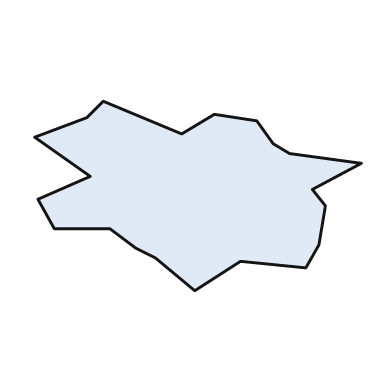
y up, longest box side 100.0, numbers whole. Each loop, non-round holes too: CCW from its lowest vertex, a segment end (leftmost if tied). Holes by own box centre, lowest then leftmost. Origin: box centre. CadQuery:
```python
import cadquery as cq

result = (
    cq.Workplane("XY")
    .moveTo(-1.0, -29.0)
    .lineTo(13.0, -20.0)
    .lineTo(33.0, -22.0)
    .lineTo(37.0, -15.0)
    .lineTo(39.0, -3.0)
    .lineTo(35.0, 2.0)
    .lineTo(50.0, 10.0)
    .lineTo(28.0, 13.0)
    .lineTo(23.0, 16.0)
    .lineTo(18.0, 23.0)
    .lineTo(5.0, 25.0)
    .lineTo(-5.0, 19.0)
    .lineTo(-29.0, 29.0)
    .lineTo(-34.0, 24.0)
    .lineTo(-50.0, 18.0)
    .lineTo(-33.0, 6.0)
    .lineTo(-49.0, -1.0)
    .lineTo(-44.0, -10.0)
    .lineTo(-27.0, -10.0)
    .lineTo(-19.0, -16.0)
    .lineTo(-13.0, -19.0)
    .close()
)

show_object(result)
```